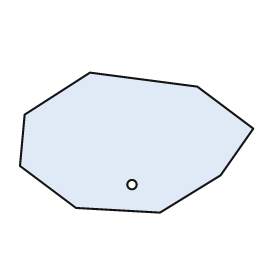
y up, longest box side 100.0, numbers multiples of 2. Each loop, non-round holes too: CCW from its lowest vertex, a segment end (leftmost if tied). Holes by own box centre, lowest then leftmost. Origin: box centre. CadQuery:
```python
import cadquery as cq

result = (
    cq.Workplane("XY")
    .moveTo(10.0, -30.0)
    .lineTo(36.0, -14.0)
    .lineTo(50.0, 6.0)
    .lineTo(26.0, 24.0)
    .lineTo(-20.0, 30.0)
    .lineTo(-48.0, 12.0)
    .lineTo(-50.0, -10.0)
    .lineTo(-26.0, -28.0)
    .close()
    .moveTo(-2.0, -18.0)
    .circle(2.0)
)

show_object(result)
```